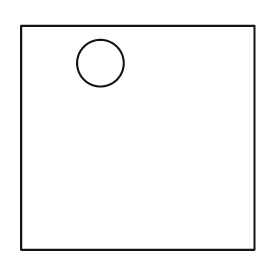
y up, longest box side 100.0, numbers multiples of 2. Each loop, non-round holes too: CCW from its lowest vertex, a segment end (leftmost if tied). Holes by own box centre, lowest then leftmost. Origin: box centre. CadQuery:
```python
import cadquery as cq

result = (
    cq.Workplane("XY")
    .moveTo(-50.0, -48.0)
    .lineTo(50.0, -48.0)
    .lineTo(50.0, 48.0)
    .lineTo(-50.0, 48.0)
    .close()
    .moveTo(-16.0, 32.0)
    .circle(10.0)
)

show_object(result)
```